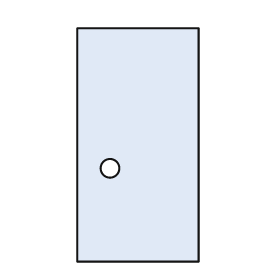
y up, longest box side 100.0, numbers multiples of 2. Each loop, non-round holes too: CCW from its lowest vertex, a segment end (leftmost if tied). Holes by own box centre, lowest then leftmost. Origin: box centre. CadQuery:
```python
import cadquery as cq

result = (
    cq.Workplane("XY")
    .moveTo(-26.0, -50.0)
    .lineTo(26.0, -50.0)
    .lineTo(26.0, 50.0)
    .lineTo(-26.0, 50.0)
    .close()
    .moveTo(-12.0, -10.0)
    .circle(4.0)
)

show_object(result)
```